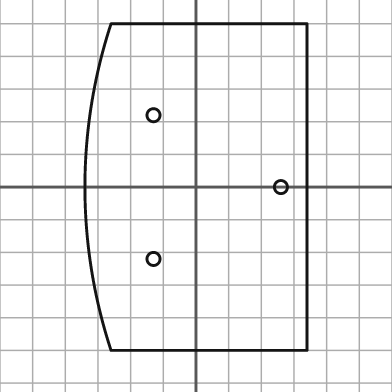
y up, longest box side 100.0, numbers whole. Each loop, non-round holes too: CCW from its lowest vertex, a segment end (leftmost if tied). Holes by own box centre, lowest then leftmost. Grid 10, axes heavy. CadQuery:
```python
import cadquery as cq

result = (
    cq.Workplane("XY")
    .moveTo(-26.0, -50.0)
    .lineTo(34.0, -50.0)
    .lineTo(34.0, 50.0)
    .lineTo(-26.0, 50.0)
    .threePointArc((-34.0, 0.0), (-26.0, -50.0))
    .close()
    .moveTo(-13.0, -22.0)
    .circle(2.0)
    .moveTo(26.0, 0.0)
    .circle(2.0)
    .moveTo(-13.0, 22.0)
    .circle(2.0)
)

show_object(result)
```